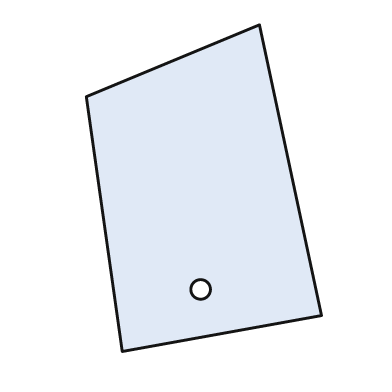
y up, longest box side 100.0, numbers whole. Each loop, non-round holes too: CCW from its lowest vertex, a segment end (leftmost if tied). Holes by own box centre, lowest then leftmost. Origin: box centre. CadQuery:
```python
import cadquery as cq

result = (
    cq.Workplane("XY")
    .moveTo(-25.0, -50.0)
    .lineTo(36.0, -39.0)
    .lineTo(17.0, 50.0)
    .lineTo(-36.0, 28.0)
    .close()
    .moveTo(-1.0, -31.0)
    .circle(3.0)
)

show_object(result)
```